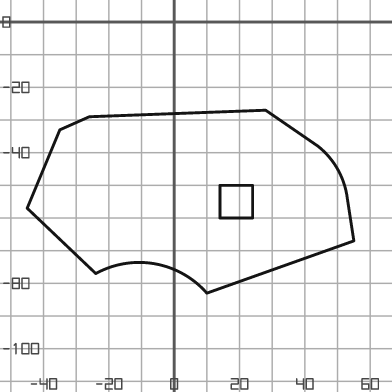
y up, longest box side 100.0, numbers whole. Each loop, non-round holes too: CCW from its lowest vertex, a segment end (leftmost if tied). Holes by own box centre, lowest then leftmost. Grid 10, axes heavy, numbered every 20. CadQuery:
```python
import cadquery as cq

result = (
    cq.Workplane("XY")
    .moveTo(10.0, -83.0)
    .lineTo(55.0, -67.0)
    .lineTo(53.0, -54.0)
    .threePointArc((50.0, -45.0), (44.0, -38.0))
    .lineTo(28.0, -27.0)
    .lineTo(-26.0, -29.0)
    .lineTo(-35.0, -33.0)
    .lineTo(-45.0, -57.0)
    .lineTo(-24.0, -77.0)
    .threePointArc((-6.0, -74.0), (10.0, -83.0))
    .close()
    .moveTo(14.0, -60.0)
    .lineTo(24.0, -60.0)
    .lineTo(24.0, -50.0)
    .lineTo(14.0, -50.0)
    .close()
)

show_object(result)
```